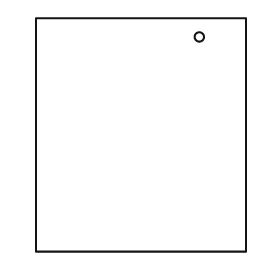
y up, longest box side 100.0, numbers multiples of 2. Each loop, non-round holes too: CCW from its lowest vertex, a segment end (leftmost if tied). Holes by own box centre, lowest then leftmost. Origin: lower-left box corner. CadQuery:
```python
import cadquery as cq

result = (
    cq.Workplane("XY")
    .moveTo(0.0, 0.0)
    .lineTo(90.0, 0.0)
    .lineTo(90.0, 100.0)
    .lineTo(0.0, 100.0)
    .close()
    .moveTo(70.0, 92.0)
    .circle(2.0)
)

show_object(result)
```